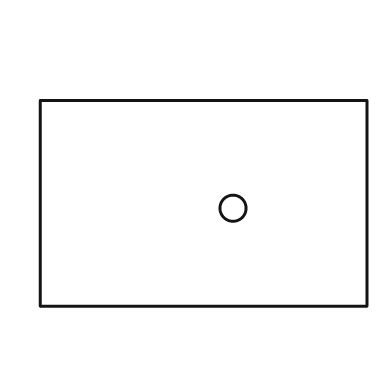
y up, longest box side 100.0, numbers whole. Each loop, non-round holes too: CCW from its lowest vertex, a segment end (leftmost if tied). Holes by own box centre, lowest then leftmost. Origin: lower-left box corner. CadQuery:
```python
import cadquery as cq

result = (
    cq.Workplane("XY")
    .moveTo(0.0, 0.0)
    .lineTo(100.0, 0.0)
    .lineTo(100.0, 63.0)
    .lineTo(0.0, 63.0)
    .close()
    .moveTo(59.0, 30.0)
    .circle(4.0)
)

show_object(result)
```